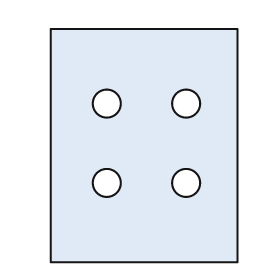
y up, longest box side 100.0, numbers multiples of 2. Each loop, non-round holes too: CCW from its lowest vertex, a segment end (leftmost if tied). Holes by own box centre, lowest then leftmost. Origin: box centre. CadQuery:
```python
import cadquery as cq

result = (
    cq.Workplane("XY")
    .moveTo(-40.0, -50.0)
    .lineTo(40.0, -50.0)
    .lineTo(40.0, 50.0)
    .lineTo(-40.0, 50.0)
    .close()
    .moveTo(-16.0, -16.0)
    .circle(6.0)
    .moveTo(18.0, -16.0)
    .circle(6.0)
    .moveTo(-16.0, 18.0)
    .circle(6.0)
    .moveTo(18.0, 18.0)
    .circle(6.0)
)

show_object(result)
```